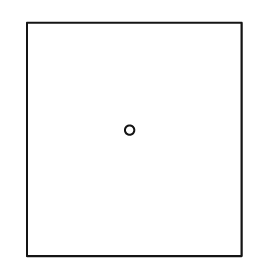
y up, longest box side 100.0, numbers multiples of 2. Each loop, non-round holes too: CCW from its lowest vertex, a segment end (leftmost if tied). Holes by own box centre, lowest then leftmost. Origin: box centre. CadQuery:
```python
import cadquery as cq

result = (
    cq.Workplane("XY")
    .moveTo(-46.0, -50.0)
    .lineTo(46.0, -50.0)
    .lineTo(46.0, 50.0)
    .lineTo(-46.0, 50.0)
    .close()
    .moveTo(-2.0, 4.0)
    .circle(2.0)
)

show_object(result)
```